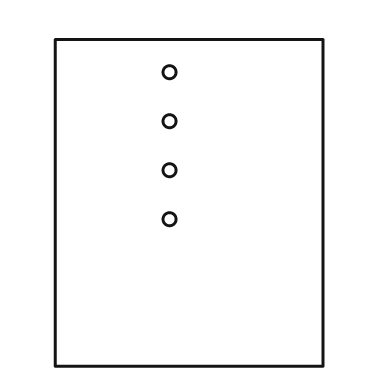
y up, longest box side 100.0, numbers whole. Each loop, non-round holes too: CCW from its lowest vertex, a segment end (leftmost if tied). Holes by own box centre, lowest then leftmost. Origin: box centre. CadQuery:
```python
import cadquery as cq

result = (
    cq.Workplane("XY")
    .moveTo(-41.0, -50.0)
    .lineTo(41.0, -50.0)
    .lineTo(41.0, 50.0)
    .lineTo(-41.0, 50.0)
    .close()
    .moveTo(-6.0, -5.0)
    .circle(2.0)
    .moveTo(-6.0, 10.0)
    .circle(2.0)
    .moveTo(-6.0, 25.0)
    .circle(2.0)
    .moveTo(-6.0, 40.0)
    .circle(2.0)
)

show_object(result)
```